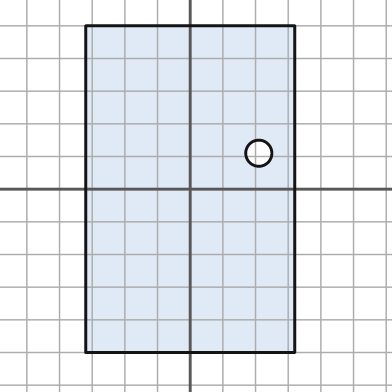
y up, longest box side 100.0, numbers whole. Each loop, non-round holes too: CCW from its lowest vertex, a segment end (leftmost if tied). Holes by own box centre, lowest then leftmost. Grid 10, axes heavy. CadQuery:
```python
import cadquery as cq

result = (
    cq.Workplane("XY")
    .moveTo(-32.0, -50.0)
    .lineTo(32.0, -50.0)
    .lineTo(32.0, 50.0)
    .lineTo(-32.0, 50.0)
    .close()
    .moveTo(21.0, 11.0)
    .circle(4.0)
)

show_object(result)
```